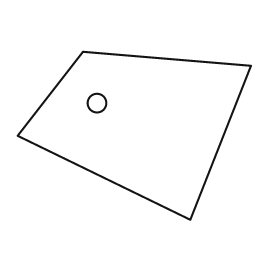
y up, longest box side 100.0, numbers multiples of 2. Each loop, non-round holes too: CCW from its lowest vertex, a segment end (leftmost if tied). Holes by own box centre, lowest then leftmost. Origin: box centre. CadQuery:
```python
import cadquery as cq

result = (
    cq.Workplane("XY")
    .moveTo(24.0, -36.0)
    .lineTo(50.0, 30.0)
    .lineTo(-22.0, 36.0)
    .lineTo(-50.0, 0.0)
    .close()
    .moveTo(-16.0, 14.0)
    .circle(4.0)
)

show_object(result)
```